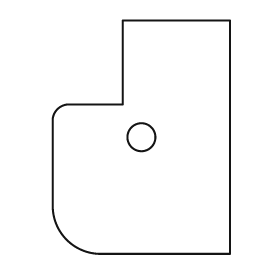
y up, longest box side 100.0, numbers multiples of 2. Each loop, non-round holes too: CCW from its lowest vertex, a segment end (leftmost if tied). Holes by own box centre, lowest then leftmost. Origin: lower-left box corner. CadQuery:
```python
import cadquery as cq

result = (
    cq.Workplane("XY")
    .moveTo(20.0, 0.0)
    .lineTo(76.0, 0.0)
    .lineTo(76.0, 100.0)
    .lineTo(30.0, 100.0)
    .lineTo(30.0, 64.0)
    .lineTo(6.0, 64.0)
    .threePointArc((2.0, 62.0), (0.0, 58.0))
    .lineTo(0.0, 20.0)
    .threePointArc((6.0, 6.0), (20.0, 0.0))
    .close()
    .moveTo(38.0, 50.0)
    .circle(6.0)
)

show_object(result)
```